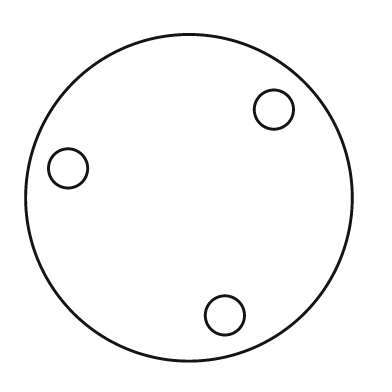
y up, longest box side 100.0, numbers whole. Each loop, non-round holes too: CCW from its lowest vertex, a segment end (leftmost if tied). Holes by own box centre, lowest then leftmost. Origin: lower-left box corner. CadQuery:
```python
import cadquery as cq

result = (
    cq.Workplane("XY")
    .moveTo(50.0, 50.0)
    .circle(50.0)
    .moveTo(61.0, 14.0)
    .circle(6.0)
    .moveTo(13.0, 59.0)
    .circle(6.0)
    .moveTo(76.0, 77.0)
    .circle(6.0)
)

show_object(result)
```